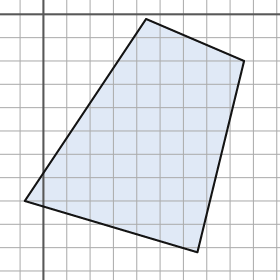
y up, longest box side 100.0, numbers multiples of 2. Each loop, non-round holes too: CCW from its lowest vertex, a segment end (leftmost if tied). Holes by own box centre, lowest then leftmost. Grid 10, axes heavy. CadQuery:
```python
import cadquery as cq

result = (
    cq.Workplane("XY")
    .moveTo(66.0, -102.0)
    .lineTo(86.0, -20.0)
    .lineTo(44.0, -2.0)
    .lineTo(-8.0, -80.0)
    .close()
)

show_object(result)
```